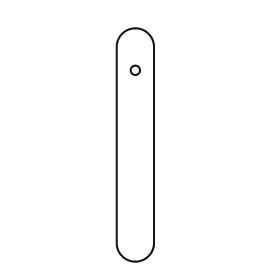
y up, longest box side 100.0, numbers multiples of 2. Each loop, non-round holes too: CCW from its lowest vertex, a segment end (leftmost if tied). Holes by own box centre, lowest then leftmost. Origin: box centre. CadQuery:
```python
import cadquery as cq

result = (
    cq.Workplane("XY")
    .moveTo(-8.0, -42.0)
    .threePointArc((0.0, -50.0), (8.0, -42.0))
    .lineTo(8.0, 42.0)
    .threePointArc((0.0, 50.0), (-8.0, 42.0))
    .close()
    .moveTo(0.0, 32.0)
    .circle(2.0)
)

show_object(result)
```